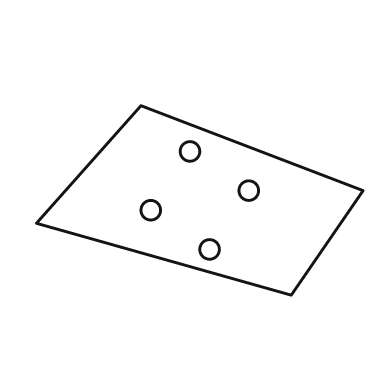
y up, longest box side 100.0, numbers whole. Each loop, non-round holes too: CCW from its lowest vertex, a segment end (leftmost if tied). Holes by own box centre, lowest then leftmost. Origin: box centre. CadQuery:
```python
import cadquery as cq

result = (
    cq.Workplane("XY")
    .moveTo(28.0, -29.0)
    .lineTo(50.0, 3.0)
    .lineTo(-18.0, 29.0)
    .lineTo(-50.0, -7.0)
    .close()
    .moveTo(3.0, -15.0)
    .circle(3.0)
    .moveTo(-15.0, -3.0)
    .circle(3.0)
    .moveTo(15.0, 3.0)
    .circle(3.0)
    .moveTo(-3.0, 15.0)
    .circle(3.0)
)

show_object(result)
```